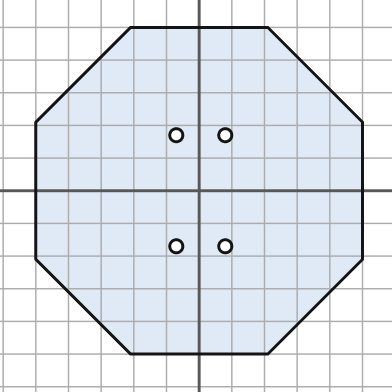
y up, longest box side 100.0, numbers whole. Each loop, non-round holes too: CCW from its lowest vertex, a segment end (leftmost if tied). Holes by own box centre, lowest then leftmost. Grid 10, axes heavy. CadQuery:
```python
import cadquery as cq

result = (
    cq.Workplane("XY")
    .moveTo(-21.0, -50.0)
    .lineTo(21.0, -50.0)
    .lineTo(50.0, -21.0)
    .lineTo(50.0, 21.0)
    .lineTo(21.0, 50.0)
    .lineTo(-21.0, 50.0)
    .lineTo(-50.0, 21.0)
    .lineTo(-50.0, -21.0)
    .close()
    .moveTo(-7.0, -17.0)
    .circle(2.0)
    .moveTo(8.0, -17.0)
    .circle(2.0)
    .moveTo(-7.0, 17.0)
    .circle(2.0)
    .moveTo(8.0, 17.0)
    .circle(2.0)
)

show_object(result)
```